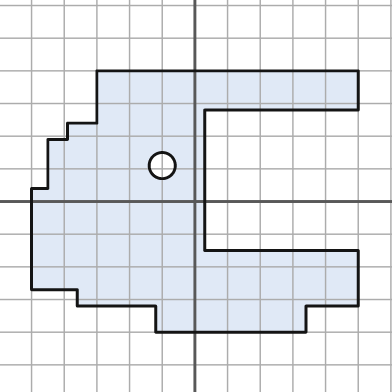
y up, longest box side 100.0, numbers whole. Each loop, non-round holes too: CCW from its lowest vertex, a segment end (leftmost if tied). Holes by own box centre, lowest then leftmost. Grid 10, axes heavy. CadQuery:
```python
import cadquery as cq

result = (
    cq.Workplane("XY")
    .moveTo(-12.0, -40.0)
    .lineTo(34.0, -40.0)
    .lineTo(34.0, -32.0)
    .lineTo(50.0, -32.0)
    .lineTo(50.0, -15.0)
    .lineTo(3.0, -15.0)
    .lineTo(3.0, 28.0)
    .lineTo(50.0, 28.0)
    .lineTo(50.0, 40.0)
    .lineTo(-30.0, 40.0)
    .lineTo(-30.0, 24.0)
    .lineTo(-39.0, 24.0)
    .lineTo(-39.0, 19.0)
    .lineTo(-45.0, 19.0)
    .lineTo(-45.0, 4.0)
    .lineTo(-50.0, 4.0)
    .lineTo(-50.0, -27.0)
    .lineTo(-36.0, -27.0)
    .lineTo(-36.0, -32.0)
    .lineTo(-12.0, -32.0)
    .close()
    .moveTo(-10.0, 11.0)
    .circle(4.0)
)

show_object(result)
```